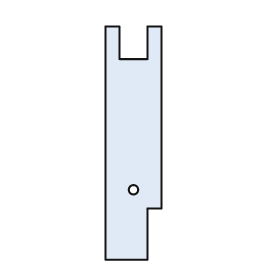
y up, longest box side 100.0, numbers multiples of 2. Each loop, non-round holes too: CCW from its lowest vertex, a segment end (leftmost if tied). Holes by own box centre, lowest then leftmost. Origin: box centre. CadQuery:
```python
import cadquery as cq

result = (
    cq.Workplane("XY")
    .moveTo(-12.0, -50.0)
    .lineTo(6.0, -50.0)
    .lineTo(6.0, -28.0)
    .lineTo(12.0, -28.0)
    .lineTo(12.0, 50.0)
    .lineTo(6.0, 50.0)
    .lineTo(6.0, 36.0)
    .lineTo(-6.0, 36.0)
    .lineTo(-6.0, 50.0)
    .lineTo(-12.0, 50.0)
    .close()
    .moveTo(0.0, -20.0)
    .circle(2.0)
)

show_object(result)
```